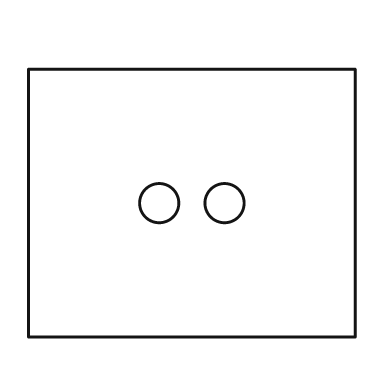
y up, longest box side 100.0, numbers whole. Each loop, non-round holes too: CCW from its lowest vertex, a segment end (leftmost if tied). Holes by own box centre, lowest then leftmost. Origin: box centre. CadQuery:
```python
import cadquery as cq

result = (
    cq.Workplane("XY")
    .moveTo(-50.0, -41.0)
    .lineTo(50.0, -41.0)
    .lineTo(50.0, 41.0)
    .lineTo(-50.0, 41.0)
    .close()
    .moveTo(-10.0, 0.0)
    .circle(6.0)
    .moveTo(10.0, 0.0)
    .circle(6.0)
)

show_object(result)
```